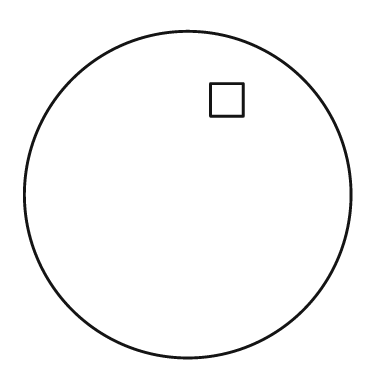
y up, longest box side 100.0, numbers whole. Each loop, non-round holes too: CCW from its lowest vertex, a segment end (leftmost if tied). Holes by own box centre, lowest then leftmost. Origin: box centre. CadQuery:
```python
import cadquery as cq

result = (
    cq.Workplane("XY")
    .moveTo(0.0, 0.0)
    .circle(50.0)
    .moveTo(7.0, 24.0)
    .lineTo(17.0, 24.0)
    .lineTo(17.0, 34.0)
    .lineTo(7.0, 34.0)
    .close()
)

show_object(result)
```